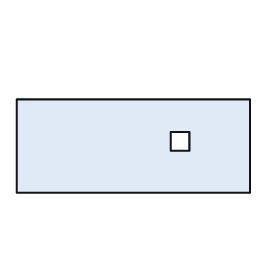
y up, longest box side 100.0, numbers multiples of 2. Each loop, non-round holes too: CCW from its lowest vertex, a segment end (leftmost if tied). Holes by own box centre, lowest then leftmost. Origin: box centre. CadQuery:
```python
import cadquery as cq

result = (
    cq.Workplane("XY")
    .moveTo(-50.0, -20.0)
    .lineTo(50.0, -20.0)
    .lineTo(50.0, 20.0)
    .lineTo(-50.0, 20.0)
    .close()
    .moveTo(16.0, -2.0)
    .lineTo(24.0, -2.0)
    .lineTo(24.0, 6.0)
    .lineTo(16.0, 6.0)
    .close()
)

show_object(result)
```